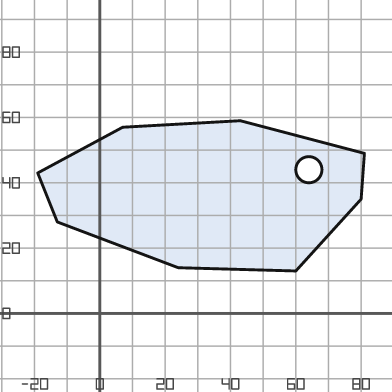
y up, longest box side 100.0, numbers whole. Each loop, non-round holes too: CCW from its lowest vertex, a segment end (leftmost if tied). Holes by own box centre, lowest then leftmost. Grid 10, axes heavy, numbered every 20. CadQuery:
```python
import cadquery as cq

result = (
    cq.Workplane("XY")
    .moveTo(60.0, 13.0)
    .lineTo(80.0, 35.0)
    .lineTo(81.0, 49.0)
    .lineTo(43.0, 59.0)
    .lineTo(7.0, 57.0)
    .lineTo(-19.0, 43.0)
    .lineTo(-13.0, 28.0)
    .lineTo(24.0, 14.0)
    .close()
    .moveTo(64.0, 44.0)
    .circle(4.0)
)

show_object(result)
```